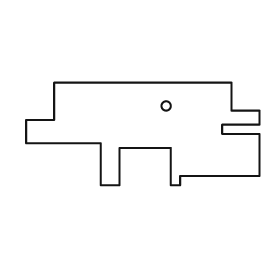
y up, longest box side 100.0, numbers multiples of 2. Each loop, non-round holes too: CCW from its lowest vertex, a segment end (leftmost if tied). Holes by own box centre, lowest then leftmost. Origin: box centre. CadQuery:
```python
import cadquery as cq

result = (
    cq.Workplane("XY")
    .moveTo(-18.0, -22.0)
    .lineTo(-10.0, -22.0)
    .lineTo(-10.0, -6.0)
    .lineTo(12.0, -6.0)
    .lineTo(12.0, -22.0)
    .lineTo(16.0, -22.0)
    .lineTo(16.0, -18.0)
    .lineTo(50.0, -18.0)
    .lineTo(50.0, 0.0)
    .lineTo(34.0, 0.0)
    .lineTo(34.0, 4.0)
    .lineTo(50.0, 4.0)
    .lineTo(50.0, 10.0)
    .lineTo(38.0, 10.0)
    .lineTo(38.0, 22.0)
    .lineTo(-38.0, 22.0)
    .lineTo(-38.0, 6.0)
    .lineTo(-50.0, 6.0)
    .lineTo(-50.0, -4.0)
    .lineTo(-18.0, -4.0)
    .close()
    .moveTo(10.0, 12.0)
    .circle(2.0)
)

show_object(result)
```